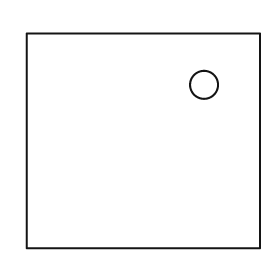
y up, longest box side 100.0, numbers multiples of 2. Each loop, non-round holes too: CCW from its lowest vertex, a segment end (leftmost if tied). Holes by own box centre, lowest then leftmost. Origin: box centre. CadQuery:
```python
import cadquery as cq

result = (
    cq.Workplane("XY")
    .moveTo(-50.0, -46.0)
    .lineTo(50.0, -46.0)
    .lineTo(50.0, 46.0)
    .lineTo(-50.0, 46.0)
    .close()
    .moveTo(26.0, 24.0)
    .circle(6.0)
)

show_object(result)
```